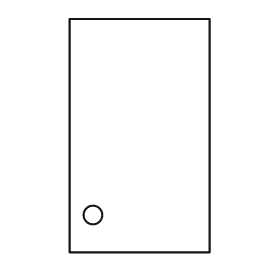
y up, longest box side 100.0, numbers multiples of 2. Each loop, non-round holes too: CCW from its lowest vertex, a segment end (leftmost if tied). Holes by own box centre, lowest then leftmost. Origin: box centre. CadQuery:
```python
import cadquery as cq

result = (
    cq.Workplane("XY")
    .moveTo(-30.0, -50.0)
    .lineTo(30.0, -50.0)
    .lineTo(30.0, 50.0)
    .lineTo(-30.0, 50.0)
    .close()
    .moveTo(-20.0, -34.0)
    .circle(4.0)
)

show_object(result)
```